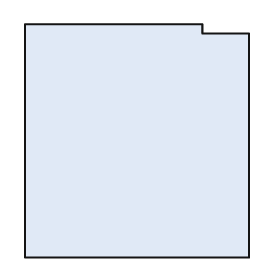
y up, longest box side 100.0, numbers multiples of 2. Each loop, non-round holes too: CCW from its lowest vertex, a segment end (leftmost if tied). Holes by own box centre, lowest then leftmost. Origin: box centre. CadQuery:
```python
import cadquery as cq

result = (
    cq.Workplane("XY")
    .moveTo(-48.0, -50.0)
    .lineTo(48.0, -50.0)
    .lineTo(48.0, 46.0)
    .lineTo(28.0, 46.0)
    .lineTo(28.0, 50.0)
    .lineTo(-48.0, 50.0)
    .close()
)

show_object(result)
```